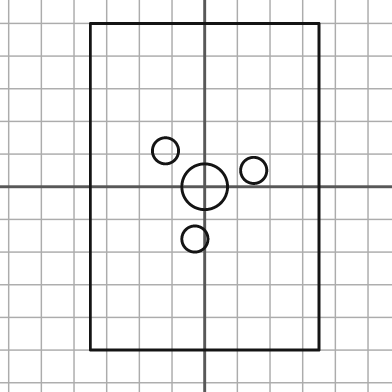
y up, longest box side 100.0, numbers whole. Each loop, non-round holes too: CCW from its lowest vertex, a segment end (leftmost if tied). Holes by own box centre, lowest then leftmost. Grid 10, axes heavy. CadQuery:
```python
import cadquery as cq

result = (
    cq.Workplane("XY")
    .moveTo(-35.0, -50.0)
    .lineTo(35.0, -50.0)
    .lineTo(35.0, 50.0)
    .lineTo(-35.0, 50.0)
    .close()
    .moveTo(-3.0, -16.0)
    .circle(4.0)
    .moveTo(0.0, 0.0)
    .circle(7.0)
    .moveTo(15.0, 5.0)
    .circle(4.0)
    .moveTo(-12.0, 11.0)
    .circle(4.0)
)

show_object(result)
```